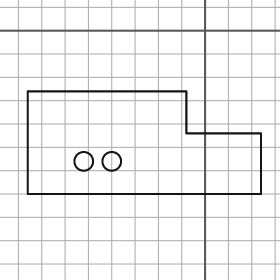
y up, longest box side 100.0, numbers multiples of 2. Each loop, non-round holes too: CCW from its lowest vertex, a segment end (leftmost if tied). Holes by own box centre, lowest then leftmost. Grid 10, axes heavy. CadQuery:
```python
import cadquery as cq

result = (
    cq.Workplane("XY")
    .moveTo(-76.0, -70.0)
    .lineTo(24.0, -70.0)
    .lineTo(24.0, -44.0)
    .lineTo(-8.0, -44.0)
    .lineTo(-8.0, -26.0)
    .lineTo(-76.0, -26.0)
    .close()
    .moveTo(-52.0, -56.0)
    .circle(4.0)
    .moveTo(-40.0, -56.0)
    .circle(4.0)
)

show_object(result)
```